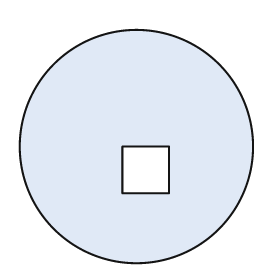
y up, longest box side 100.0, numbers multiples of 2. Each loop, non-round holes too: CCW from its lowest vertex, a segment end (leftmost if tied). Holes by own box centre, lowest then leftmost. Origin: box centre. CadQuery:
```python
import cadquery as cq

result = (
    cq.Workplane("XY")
    .moveTo(0.0, 0.0)
    .circle(50.0)
    .moveTo(-6.0, -20.0)
    .lineTo(14.0, -20.0)
    .lineTo(14.0, 0.0)
    .lineTo(-6.0, 0.0)
    .close()
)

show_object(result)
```